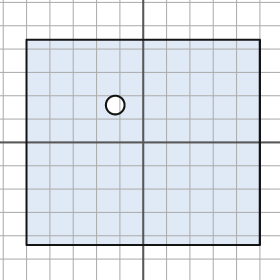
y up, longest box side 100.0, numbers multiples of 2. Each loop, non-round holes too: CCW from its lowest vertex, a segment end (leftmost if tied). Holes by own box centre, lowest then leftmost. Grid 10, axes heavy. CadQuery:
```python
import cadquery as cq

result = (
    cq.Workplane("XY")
    .moveTo(-50.0, -44.0)
    .lineTo(50.0, -44.0)
    .lineTo(50.0, 44.0)
    .lineTo(-50.0, 44.0)
    .close()
    .moveTo(-12.0, 16.0)
    .circle(4.0)
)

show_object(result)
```